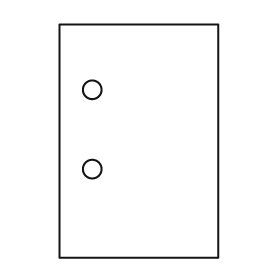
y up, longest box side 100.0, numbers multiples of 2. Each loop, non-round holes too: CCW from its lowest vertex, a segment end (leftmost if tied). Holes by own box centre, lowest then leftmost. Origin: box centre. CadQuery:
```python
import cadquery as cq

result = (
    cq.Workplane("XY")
    .moveTo(-34.0, -50.0)
    .lineTo(34.0, -50.0)
    .lineTo(34.0, 50.0)
    .lineTo(-34.0, 50.0)
    .close()
    .moveTo(-20.0, -12.0)
    .circle(4.0)
    .moveTo(-20.0, 22.0)
    .circle(4.0)
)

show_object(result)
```